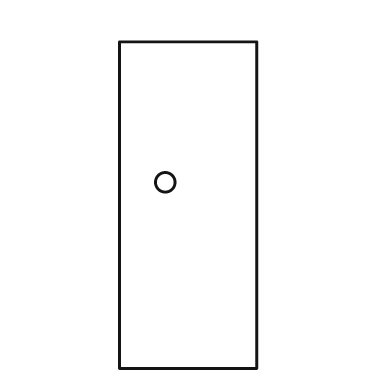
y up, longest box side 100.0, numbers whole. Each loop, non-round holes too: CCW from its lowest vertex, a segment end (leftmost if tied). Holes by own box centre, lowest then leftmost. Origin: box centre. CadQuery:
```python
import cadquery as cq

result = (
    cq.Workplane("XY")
    .moveTo(-21.0, -50.0)
    .lineTo(21.0, -50.0)
    .lineTo(21.0, 50.0)
    .lineTo(-21.0, 50.0)
    .close()
    .moveTo(-7.0, 7.0)
    .circle(3.0)
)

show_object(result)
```